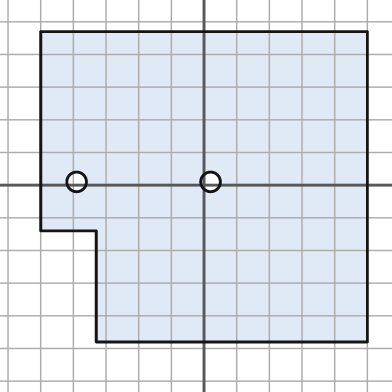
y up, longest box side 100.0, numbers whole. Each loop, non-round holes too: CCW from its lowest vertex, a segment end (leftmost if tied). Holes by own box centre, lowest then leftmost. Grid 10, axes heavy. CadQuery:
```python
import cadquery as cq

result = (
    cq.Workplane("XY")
    .moveTo(-33.0, -48.0)
    .lineTo(50.0, -48.0)
    .lineTo(50.0, 47.0)
    .lineTo(-50.0, 47.0)
    .lineTo(-50.0, -14.0)
    .lineTo(-33.0, -14.0)
    .close()
    .moveTo(-39.0, 1.0)
    .circle(3.0)
    .moveTo(2.0, 1.0)
    .circle(3.0)
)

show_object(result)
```